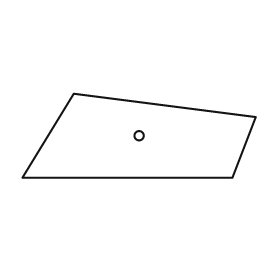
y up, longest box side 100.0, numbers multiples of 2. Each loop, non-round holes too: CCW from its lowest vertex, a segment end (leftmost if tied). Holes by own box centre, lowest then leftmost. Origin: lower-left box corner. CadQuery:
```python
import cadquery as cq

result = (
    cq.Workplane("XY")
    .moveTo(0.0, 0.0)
    .lineTo(90.0, 0.0)
    .lineTo(100.0, 26.0)
    .lineTo(22.0, 36.0)
    .close()
    .moveTo(50.0, 18.0)
    .circle(2.0)
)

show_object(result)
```